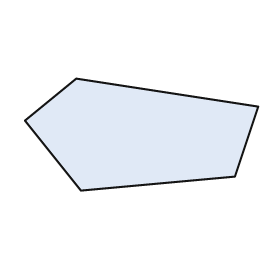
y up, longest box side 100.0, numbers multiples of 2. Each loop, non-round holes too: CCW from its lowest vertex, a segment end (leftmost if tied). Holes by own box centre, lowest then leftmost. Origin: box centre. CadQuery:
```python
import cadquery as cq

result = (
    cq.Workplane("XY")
    .moveTo(-26.0, -24.0)
    .lineTo(40.0, -18.0)
    .lineTo(50.0, 12.0)
    .lineTo(-28.0, 24.0)
    .lineTo(-50.0, 6.0)
    .close()
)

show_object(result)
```